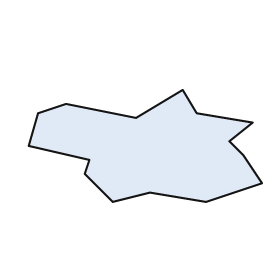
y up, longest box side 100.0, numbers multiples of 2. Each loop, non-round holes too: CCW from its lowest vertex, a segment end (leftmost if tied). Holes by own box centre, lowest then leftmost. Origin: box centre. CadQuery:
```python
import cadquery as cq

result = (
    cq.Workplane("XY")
    .moveTo(-14.0, -24.0)
    .lineTo(2.0, -20.0)
    .lineTo(26.0, -24.0)
    .lineTo(50.0, -16.0)
    .lineTo(42.0, -4.0)
    .lineTo(36.0, 2.0)
    .lineTo(46.0, 10.0)
    .lineTo(22.0, 14.0)
    .lineTo(16.0, 24.0)
    .lineTo(-4.0, 12.0)
    .lineTo(-34.0, 18.0)
    .lineTo(-46.0, 14.0)
    .lineTo(-50.0, 0.0)
    .lineTo(-24.0, -6.0)
    .lineTo(-26.0, -12.0)
    .close()
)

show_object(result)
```